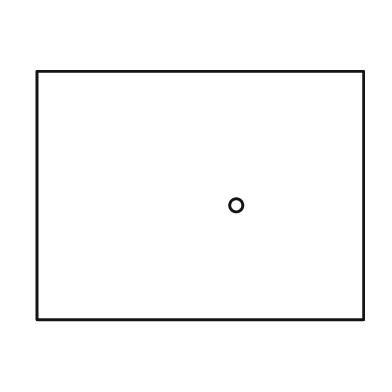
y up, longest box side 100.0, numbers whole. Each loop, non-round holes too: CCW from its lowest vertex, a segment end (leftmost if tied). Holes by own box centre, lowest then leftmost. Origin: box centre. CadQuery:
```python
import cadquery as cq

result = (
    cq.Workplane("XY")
    .moveTo(-50.0, -38.0)
    .lineTo(50.0, -38.0)
    .lineTo(50.0, 38.0)
    .lineTo(-50.0, 38.0)
    .close()
    .moveTo(11.0, -3.0)
    .circle(2.0)
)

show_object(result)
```